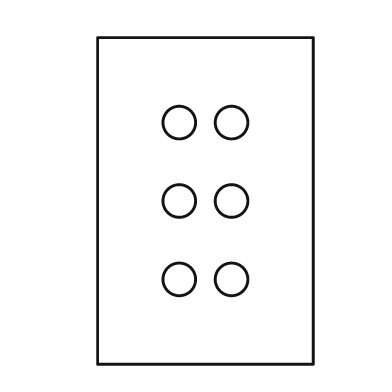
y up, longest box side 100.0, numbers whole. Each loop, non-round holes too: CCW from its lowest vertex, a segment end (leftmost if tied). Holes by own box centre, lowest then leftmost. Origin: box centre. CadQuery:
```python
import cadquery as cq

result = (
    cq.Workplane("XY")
    .moveTo(-33.0, -50.0)
    .lineTo(33.0, -50.0)
    .lineTo(33.0, 50.0)
    .lineTo(-33.0, 50.0)
    .close()
    .moveTo(-8.0, -24.0)
    .circle(5.0)
    .moveTo(8.0, -24.0)
    .circle(5.0)
    .moveTo(-8.0, 0.0)
    .circle(5.0)
    .moveTo(8.0, 0.0)
    .circle(5.0)
    .moveTo(-8.0, 24.0)
    .circle(5.0)
    .moveTo(8.0, 24.0)
    .circle(5.0)
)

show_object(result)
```